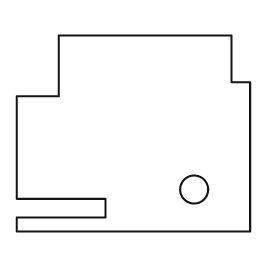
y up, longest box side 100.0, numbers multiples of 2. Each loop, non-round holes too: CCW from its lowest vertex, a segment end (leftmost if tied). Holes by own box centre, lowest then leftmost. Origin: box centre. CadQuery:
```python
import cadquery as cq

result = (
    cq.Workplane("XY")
    .moveTo(-50.0, -42.0)
    .lineTo(50.0, -42.0)
    .lineTo(50.0, 22.0)
    .lineTo(42.0, 22.0)
    .lineTo(42.0, 42.0)
    .lineTo(-32.0, 42.0)
    .lineTo(-32.0, 16.0)
    .lineTo(-50.0, 16.0)
    .lineTo(-50.0, -28.0)
    .lineTo(-12.0, -28.0)
    .lineTo(-12.0, -36.0)
    .lineTo(-50.0, -36.0)
    .close()
    .moveTo(26.0, -24.0)
    .circle(6.0)
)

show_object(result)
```